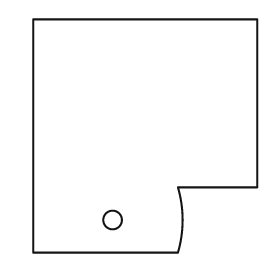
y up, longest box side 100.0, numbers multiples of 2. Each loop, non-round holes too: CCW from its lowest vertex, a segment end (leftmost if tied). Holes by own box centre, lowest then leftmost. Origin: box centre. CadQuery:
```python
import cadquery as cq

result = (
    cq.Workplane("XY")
    .moveTo(-48.0, -50.0)
    .lineTo(14.0, -50.0)
    .threePointArc((16.0, -36.0), (14.0, -22.0))
    .lineTo(48.0, -22.0)
    .lineTo(48.0, 50.0)
    .lineTo(-48.0, 50.0)
    .close()
    .moveTo(-14.0, -36.0)
    .circle(4.0)
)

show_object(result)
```